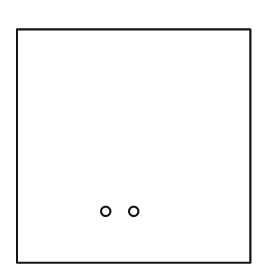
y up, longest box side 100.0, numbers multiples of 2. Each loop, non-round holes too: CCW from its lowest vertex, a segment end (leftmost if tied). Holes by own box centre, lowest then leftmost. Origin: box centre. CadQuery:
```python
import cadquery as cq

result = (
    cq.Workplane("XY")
    .moveTo(-50.0, -50.0)
    .lineTo(50.0, -50.0)
    .lineTo(50.0, 50.0)
    .lineTo(-50.0, 50.0)
    .close()
    .moveTo(-12.0, -28.0)
    .circle(2.0)
    .moveTo(0.0, -28.0)
    .circle(2.0)
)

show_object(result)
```